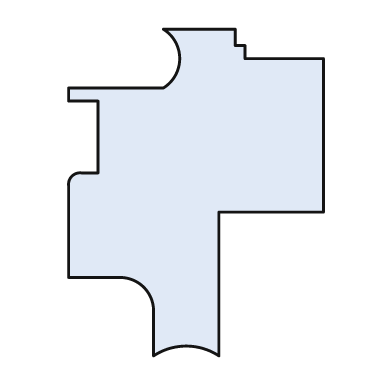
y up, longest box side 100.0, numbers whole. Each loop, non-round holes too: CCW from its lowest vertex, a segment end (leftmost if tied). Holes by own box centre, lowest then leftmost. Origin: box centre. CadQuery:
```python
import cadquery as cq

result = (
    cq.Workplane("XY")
    .moveTo(-13.0, -50.0)
    .threePointArc((-3.0, -47.0), (7.0, -50.0))
    .lineTo(7.0, -6.0)
    .lineTo(39.0, -6.0)
    .lineTo(39.0, 41.0)
    .lineTo(15.0, 41.0)
    .lineTo(15.0, 45.0)
    .lineTo(12.0, 45.0)
    .lineTo(12.0, 50.0)
    .lineTo(-10.0, 50.0)
    .threePointArc((-5.0, 41.0), (-10.0, 32.0))
    .lineTo(-39.0, 32.0)
    .lineTo(-39.0, 28.0)
    .lineTo(-30.0, 28.0)
    .lineTo(-30.0, 6.0)
    .lineTo(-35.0, 6.0)
    .threePointArc((-38.0, 5.0), (-39.0, 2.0))
    .lineTo(-39.0, -26.0)
    .lineTo(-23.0, -26.0)
    .threePointArc((-16.0, -29.0), (-13.0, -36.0))
    .close()
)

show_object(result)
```